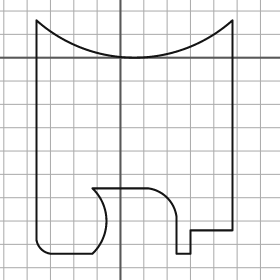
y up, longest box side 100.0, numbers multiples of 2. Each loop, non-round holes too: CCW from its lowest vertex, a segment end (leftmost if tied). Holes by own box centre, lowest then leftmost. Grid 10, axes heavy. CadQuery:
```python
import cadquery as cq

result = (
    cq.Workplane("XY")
    .moveTo(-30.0, -84.0)
    .lineTo(-12.0, -84.0)
    .threePointArc((-6.0, -70.0), (-12.0, -56.0))
    .lineTo(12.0, -56.0)
    .threePointArc((20.0, -60.0), (24.0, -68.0))
    .lineTo(24.0, -84.0)
    .lineTo(30.0, -84.0)
    .lineTo(30.0, -74.0)
    .lineTo(48.0, -74.0)
    .lineTo(48.0, 16.0)
    .threePointArc((6.0, 0.0), (-36.0, 16.0))
    .lineTo(-36.0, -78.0)
    .threePointArc((-34.0, -82.0), (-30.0, -84.0))
    .close()
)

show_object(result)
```